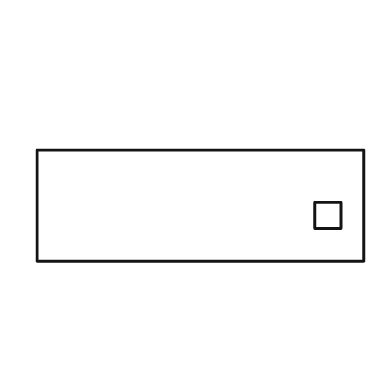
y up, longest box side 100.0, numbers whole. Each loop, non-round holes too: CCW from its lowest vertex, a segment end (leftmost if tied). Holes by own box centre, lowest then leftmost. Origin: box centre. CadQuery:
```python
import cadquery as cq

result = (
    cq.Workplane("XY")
    .moveTo(-50.0, -17.0)
    .lineTo(50.0, -17.0)
    .lineTo(50.0, 17.0)
    .lineTo(-50.0, 17.0)
    .close()
    .moveTo(35.0, -7.0)
    .lineTo(43.0, -7.0)
    .lineTo(43.0, 1.0)
    .lineTo(35.0, 1.0)
    .close()
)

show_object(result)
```